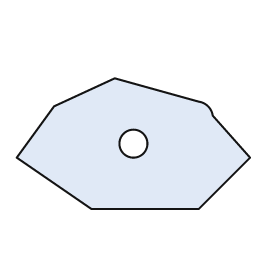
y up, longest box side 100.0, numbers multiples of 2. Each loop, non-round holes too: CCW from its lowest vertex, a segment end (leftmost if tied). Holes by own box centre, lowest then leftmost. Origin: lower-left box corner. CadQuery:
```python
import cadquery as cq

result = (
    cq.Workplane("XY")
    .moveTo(32.0, 0.0)
    .lineTo(78.0, 0.0)
    .lineTo(100.0, 22.0)
    .lineTo(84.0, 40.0)
    .threePointArc((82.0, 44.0), (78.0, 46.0))
    .lineTo(42.0, 56.0)
    .lineTo(16.0, 44.0)
    .lineTo(0.0, 22.0)
    .close()
    .moveTo(50.0, 28.0)
    .circle(6.0)
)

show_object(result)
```